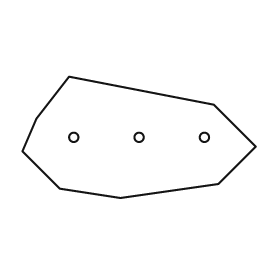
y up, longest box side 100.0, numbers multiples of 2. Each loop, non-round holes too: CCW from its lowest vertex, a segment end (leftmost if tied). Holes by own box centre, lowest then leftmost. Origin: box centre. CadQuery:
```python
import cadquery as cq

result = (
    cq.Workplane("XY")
    .moveTo(-8.0, -26.0)
    .lineTo(34.0, -20.0)
    .lineTo(50.0, -4.0)
    .lineTo(32.0, 14.0)
    .lineTo(-30.0, 26.0)
    .lineTo(-44.0, 8.0)
    .lineTo(-50.0, -6.0)
    .lineTo(-34.0, -22.0)
    .close()
    .moveTo(-28.0, 0.0)
    .circle(2.0)
    .moveTo(0.0, 0.0)
    .circle(2.0)
    .moveTo(28.0, 0.0)
    .circle(2.0)
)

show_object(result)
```